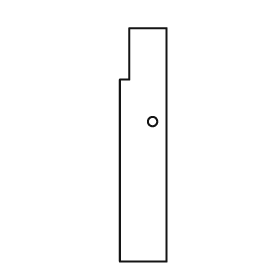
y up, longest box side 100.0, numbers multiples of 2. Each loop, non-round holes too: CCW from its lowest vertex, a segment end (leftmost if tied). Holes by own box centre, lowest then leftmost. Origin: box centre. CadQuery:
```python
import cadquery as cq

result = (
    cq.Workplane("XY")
    .moveTo(-10.0, -50.0)
    .lineTo(10.0, -50.0)
    .lineTo(10.0, 50.0)
    .lineTo(-6.0, 50.0)
    .lineTo(-6.0, 28.0)
    .lineTo(-10.0, 28.0)
    .close()
    .moveTo(4.0, 10.0)
    .circle(2.0)
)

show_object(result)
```